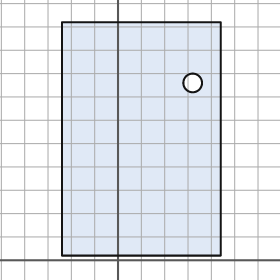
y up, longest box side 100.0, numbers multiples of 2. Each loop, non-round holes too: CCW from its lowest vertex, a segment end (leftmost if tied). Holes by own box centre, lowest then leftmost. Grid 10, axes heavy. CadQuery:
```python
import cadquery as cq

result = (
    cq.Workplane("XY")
    .moveTo(-24.0, 2.0)
    .lineTo(44.0, 2.0)
    .lineTo(44.0, 102.0)
    .lineTo(-24.0, 102.0)
    .close()
    .moveTo(32.0, 76.0)
    .circle(4.0)
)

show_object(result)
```